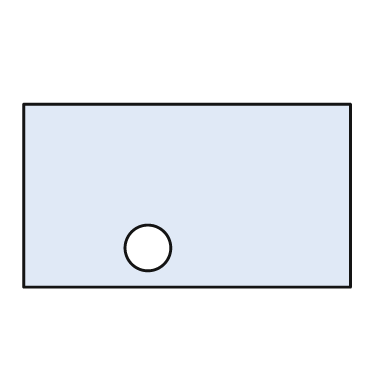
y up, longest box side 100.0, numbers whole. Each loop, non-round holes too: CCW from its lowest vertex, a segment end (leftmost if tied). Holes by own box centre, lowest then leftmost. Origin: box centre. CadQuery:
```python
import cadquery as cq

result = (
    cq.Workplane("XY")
    .moveTo(-50.0, -28.0)
    .lineTo(50.0, -28.0)
    .lineTo(50.0, 28.0)
    .lineTo(-50.0, 28.0)
    .close()
    .moveTo(-12.0, -16.0)
    .circle(7.0)
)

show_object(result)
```